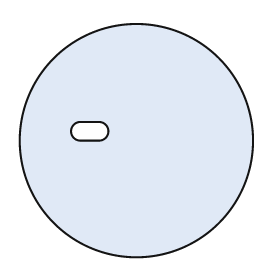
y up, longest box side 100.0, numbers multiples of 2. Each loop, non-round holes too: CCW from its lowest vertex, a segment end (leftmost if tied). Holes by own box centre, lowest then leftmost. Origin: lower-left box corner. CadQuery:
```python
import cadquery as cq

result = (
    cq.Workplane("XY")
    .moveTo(50.0, 50.0)
    .circle(50.0)
    .moveTo(26.0, 50.0)
    .lineTo(34.0, 50.0)
    .threePointArc((38.0, 54.0), (34.0, 58.0))
    .lineTo(26.0, 58.0)
    .threePointArc((22.0, 54.0), (26.0, 50.0))
    .close()
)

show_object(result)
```